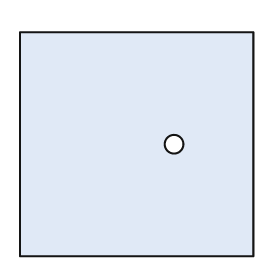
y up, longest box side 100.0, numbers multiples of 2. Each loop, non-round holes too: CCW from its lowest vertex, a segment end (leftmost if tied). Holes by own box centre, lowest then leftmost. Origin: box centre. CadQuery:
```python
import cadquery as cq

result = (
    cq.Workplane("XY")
    .moveTo(-50.0, -48.0)
    .lineTo(50.0, -48.0)
    .lineTo(50.0, 48.0)
    .lineTo(-50.0, 48.0)
    .close()
    .moveTo(16.0, 0.0)
    .circle(4.0)
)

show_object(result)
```